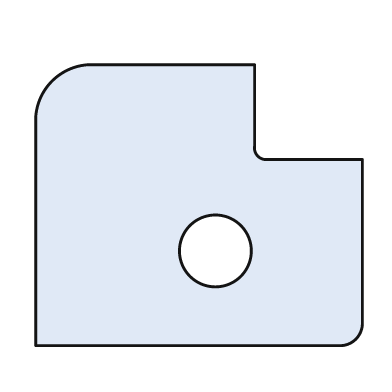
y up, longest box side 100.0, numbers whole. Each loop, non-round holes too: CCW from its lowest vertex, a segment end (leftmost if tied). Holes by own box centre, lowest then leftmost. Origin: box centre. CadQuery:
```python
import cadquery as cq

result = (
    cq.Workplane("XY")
    .moveTo(-50.0, -43.0)
    .lineTo(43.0, -43.0)
    .threePointArc((48.0, -41.0), (50.0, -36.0))
    .lineTo(50.0, 14.0)
    .lineTo(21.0, 14.0)
    .threePointArc((18.0, 15.0), (17.0, 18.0))
    .lineTo(17.0, 43.0)
    .lineTo(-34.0, 43.0)
    .threePointArc((-45.0, 38.0), (-50.0, 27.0))
    .close()
    .moveTo(5.0, -14.0)
    .circle(11.0)
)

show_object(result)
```